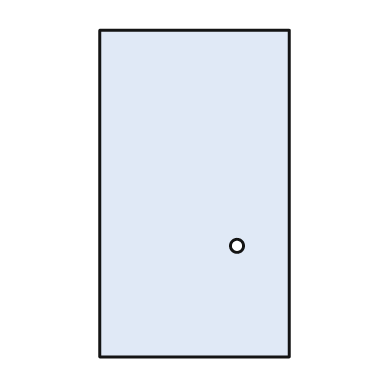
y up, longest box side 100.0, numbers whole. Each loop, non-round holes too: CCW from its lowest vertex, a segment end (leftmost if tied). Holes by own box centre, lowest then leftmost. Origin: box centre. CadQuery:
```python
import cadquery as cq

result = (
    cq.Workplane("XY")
    .moveTo(-29.0, -50.0)
    .lineTo(29.0, -50.0)
    .lineTo(29.0, 50.0)
    .lineTo(-29.0, 50.0)
    .close()
    .moveTo(13.0, -16.0)
    .circle(2.0)
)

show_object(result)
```